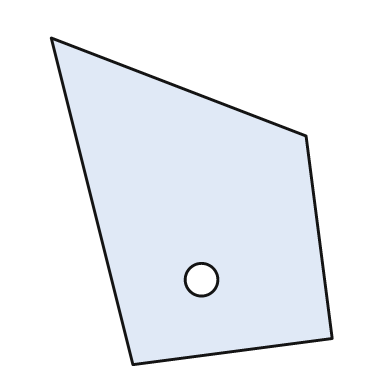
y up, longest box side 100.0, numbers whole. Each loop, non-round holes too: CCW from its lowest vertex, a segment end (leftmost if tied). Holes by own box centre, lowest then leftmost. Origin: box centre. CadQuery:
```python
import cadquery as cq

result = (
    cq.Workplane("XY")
    .moveTo(-18.0, -50.0)
    .lineTo(43.0, -42.0)
    .lineTo(35.0, 20.0)
    .lineTo(-43.0, 50.0)
    .close()
    .moveTo(3.0, -24.0)
    .circle(5.0)
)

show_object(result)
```